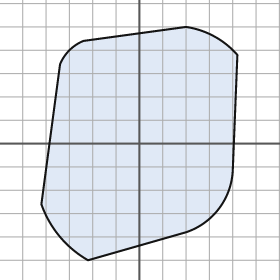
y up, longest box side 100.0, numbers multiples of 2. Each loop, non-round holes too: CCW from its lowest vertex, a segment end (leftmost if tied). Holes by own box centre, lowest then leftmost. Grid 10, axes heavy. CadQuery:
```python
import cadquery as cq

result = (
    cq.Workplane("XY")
    .moveTo(-22.0, -50.0)
    .lineTo(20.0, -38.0)
    .threePointArc((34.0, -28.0), (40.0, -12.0))
    .lineTo(42.0, 38.0)
    .threePointArc((32.0, 46.0), (20.0, 50.0))
    .lineTo(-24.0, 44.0)
    .threePointArc((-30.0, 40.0), (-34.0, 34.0))
    .lineTo(-42.0, -26.0)
    .threePointArc((-34.0, -40.0), (-22.0, -50.0))
    .close()
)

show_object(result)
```